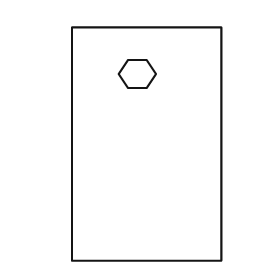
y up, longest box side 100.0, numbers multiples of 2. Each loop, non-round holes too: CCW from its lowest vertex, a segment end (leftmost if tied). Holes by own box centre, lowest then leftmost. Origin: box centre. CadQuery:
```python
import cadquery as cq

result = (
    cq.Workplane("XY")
    .moveTo(-32.0, -50.0)
    .lineTo(32.0, -50.0)
    .lineTo(32.0, 50.0)
    .lineTo(-32.0, 50.0)
    .close()
    .moveTo(-8.0, 24.0)
    .lineTo(0.0, 24.0)
    .lineTo(4.0, 30.0)
    .lineTo(0.0, 36.0)
    .lineTo(-8.0, 36.0)
    .lineTo(-12.0, 30.0)
    .close()
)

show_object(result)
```